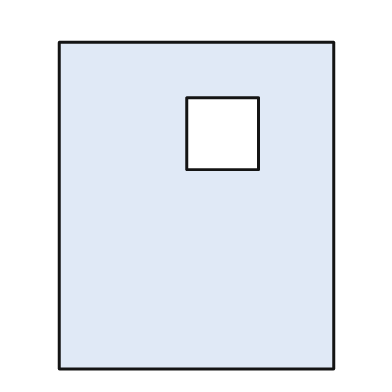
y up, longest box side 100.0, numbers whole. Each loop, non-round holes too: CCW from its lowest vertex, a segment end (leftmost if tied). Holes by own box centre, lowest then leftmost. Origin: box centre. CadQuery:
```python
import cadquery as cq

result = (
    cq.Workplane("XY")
    .moveTo(-42.0, -50.0)
    .lineTo(42.0, -50.0)
    .lineTo(42.0, 50.0)
    .lineTo(-42.0, 50.0)
    .close()
    .moveTo(-3.0, 11.0)
    .lineTo(19.0, 11.0)
    .lineTo(19.0, 33.0)
    .lineTo(-3.0, 33.0)
    .close()
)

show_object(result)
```